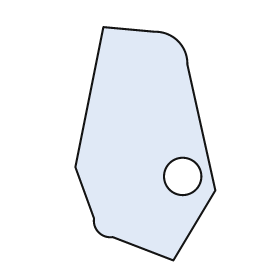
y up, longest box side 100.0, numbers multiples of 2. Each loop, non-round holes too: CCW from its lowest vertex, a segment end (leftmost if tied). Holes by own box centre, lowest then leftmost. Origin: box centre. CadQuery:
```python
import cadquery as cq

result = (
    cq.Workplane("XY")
    .moveTo(12.0, -50.0)
    .lineTo(30.0, -20.0)
    .lineTo(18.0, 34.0)
    .threePointArc((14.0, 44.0), (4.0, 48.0))
    .lineTo(-18.0, 50.0)
    .lineTo(-30.0, -10.0)
    .lineTo(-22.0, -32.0)
    .threePointArc((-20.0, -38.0), (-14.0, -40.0))
    .close()
    .moveTo(16.0, -14.0)
    .circle(8.0)
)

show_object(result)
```